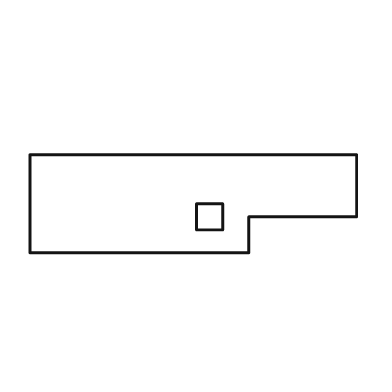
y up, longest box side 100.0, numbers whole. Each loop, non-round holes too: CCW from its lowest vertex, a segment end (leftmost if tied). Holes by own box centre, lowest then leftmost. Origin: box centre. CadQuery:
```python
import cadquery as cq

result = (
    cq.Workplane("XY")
    .moveTo(-50.0, -15.0)
    .lineTo(17.0, -15.0)
    .lineTo(17.0, -4.0)
    .lineTo(50.0, -4.0)
    .lineTo(50.0, 15.0)
    .lineTo(-50.0, 15.0)
    .close()
    .moveTo(1.0, -8.0)
    .lineTo(9.0, -8.0)
    .lineTo(9.0, 0.0)
    .lineTo(1.0, 0.0)
    .close()
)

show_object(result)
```